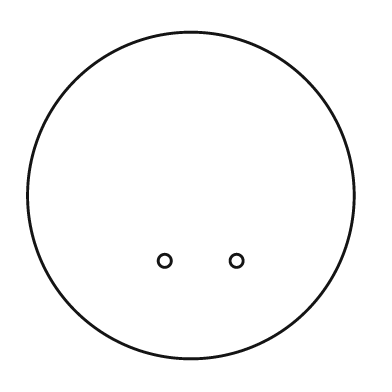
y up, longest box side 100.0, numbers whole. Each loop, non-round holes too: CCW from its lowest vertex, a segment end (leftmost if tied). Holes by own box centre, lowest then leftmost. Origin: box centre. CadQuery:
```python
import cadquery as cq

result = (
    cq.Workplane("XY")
    .moveTo(0.0, 0.0)
    .circle(50.0)
    .moveTo(-8.0, -20.0)
    .circle(2.0)
    .moveTo(14.0, -20.0)
    .circle(2.0)
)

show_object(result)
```